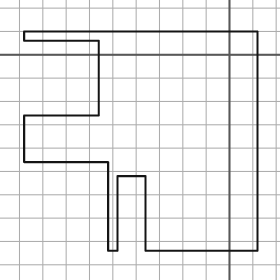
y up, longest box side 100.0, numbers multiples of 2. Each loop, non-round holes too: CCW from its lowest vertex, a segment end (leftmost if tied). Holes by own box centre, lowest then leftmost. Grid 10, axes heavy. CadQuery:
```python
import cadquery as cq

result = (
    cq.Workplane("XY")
    .moveTo(-52.0, -84.0)
    .lineTo(-48.0, -84.0)
    .lineTo(-48.0, -52.0)
    .lineTo(-36.0, -52.0)
    .lineTo(-36.0, -84.0)
    .lineTo(12.0, -84.0)
    .lineTo(12.0, 10.0)
    .lineTo(-88.0, 10.0)
    .lineTo(-88.0, 6.0)
    .lineTo(-56.0, 6.0)
    .lineTo(-56.0, -26.0)
    .lineTo(-88.0, -26.0)
    .lineTo(-88.0, -46.0)
    .lineTo(-52.0, -46.0)
    .close()
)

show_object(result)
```